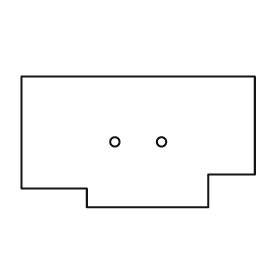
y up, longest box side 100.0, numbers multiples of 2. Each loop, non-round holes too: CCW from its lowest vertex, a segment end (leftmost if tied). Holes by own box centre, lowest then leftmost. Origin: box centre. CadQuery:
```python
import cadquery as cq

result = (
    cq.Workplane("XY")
    .moveTo(-22.0, -28.0)
    .lineTo(30.0, -28.0)
    .lineTo(30.0, -14.0)
    .lineTo(50.0, -14.0)
    .lineTo(50.0, 28.0)
    .lineTo(-50.0, 28.0)
    .lineTo(-50.0, -20.0)
    .lineTo(-22.0, -20.0)
    .close()
    .moveTo(-10.0, 0.0)
    .circle(2.0)
    .moveTo(10.0, 0.0)
    .circle(2.0)
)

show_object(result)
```